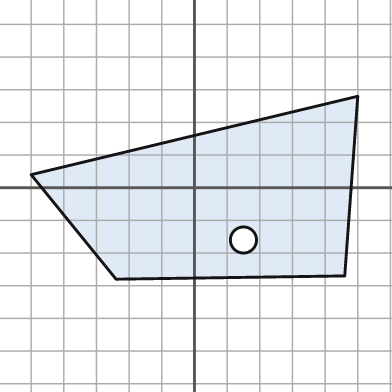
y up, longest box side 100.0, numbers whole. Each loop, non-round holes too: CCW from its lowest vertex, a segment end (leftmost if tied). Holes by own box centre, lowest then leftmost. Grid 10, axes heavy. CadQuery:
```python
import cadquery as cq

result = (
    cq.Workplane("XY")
    .moveTo(-24.0, -28.0)
    .lineTo(46.0, -27.0)
    .lineTo(50.0, 28.0)
    .lineTo(-50.0, 4.0)
    .close()
    .moveTo(15.0, -16.0)
    .circle(4.0)
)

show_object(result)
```